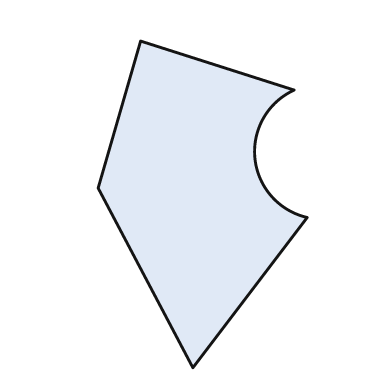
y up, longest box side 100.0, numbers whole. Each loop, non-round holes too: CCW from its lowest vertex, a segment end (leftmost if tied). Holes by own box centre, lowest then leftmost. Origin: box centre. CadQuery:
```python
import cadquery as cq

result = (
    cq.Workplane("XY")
    .moveTo(-3.0, -50.0)
    .lineTo(32.0, -4.0)
    .threePointArc((16.0, 14.0), (28.0, 35.0))
    .lineTo(-19.0, 50.0)
    .lineTo(-32.0, 5.0)
    .close()
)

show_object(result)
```